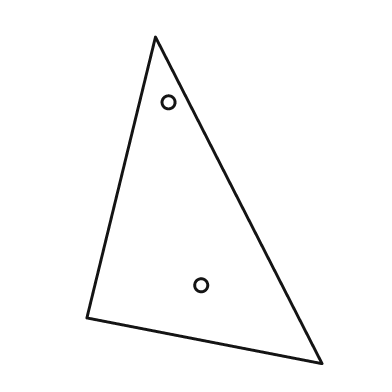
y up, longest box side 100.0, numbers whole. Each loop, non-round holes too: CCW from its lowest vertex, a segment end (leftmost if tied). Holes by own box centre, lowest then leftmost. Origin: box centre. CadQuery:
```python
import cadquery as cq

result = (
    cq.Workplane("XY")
    .moveTo(36.0, -50.0)
    .lineTo(-15.0, 50.0)
    .lineTo(-36.0, -36.0)
    .close()
    .moveTo(-1.0, -26.0)
    .circle(2.0)
    .moveTo(-11.0, 30.0)
    .circle(2.0)
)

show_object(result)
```